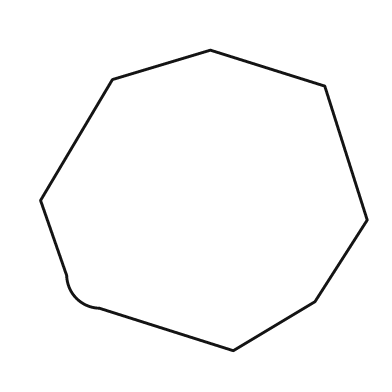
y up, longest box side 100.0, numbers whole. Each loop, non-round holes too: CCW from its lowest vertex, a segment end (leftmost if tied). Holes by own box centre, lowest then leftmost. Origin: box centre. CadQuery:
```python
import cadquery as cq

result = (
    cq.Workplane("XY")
    .moveTo(9.0, -46.0)
    .lineTo(34.0, -31.0)
    .lineTo(50.0, -6.0)
    .lineTo(37.0, 35.0)
    .lineTo(2.0, 46.0)
    .lineTo(-28.0, 37.0)
    .lineTo(-50.0, 0.0)
    .lineTo(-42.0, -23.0)
    .threePointArc((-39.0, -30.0), (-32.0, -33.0))
    .close()
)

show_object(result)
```